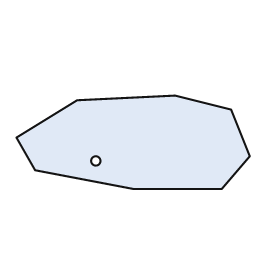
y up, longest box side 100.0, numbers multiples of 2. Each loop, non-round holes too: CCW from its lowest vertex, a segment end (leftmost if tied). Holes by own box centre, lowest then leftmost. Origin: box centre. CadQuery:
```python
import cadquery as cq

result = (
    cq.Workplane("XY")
    .moveTo(0.0, -20.0)
    .lineTo(38.0, -20.0)
    .lineTo(50.0, -6.0)
    .lineTo(42.0, 14.0)
    .lineTo(18.0, 20.0)
    .lineTo(-24.0, 18.0)
    .lineTo(-50.0, 2.0)
    .lineTo(-42.0, -12.0)
    .close()
    .moveTo(-16.0, -8.0)
    .circle(2.0)
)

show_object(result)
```